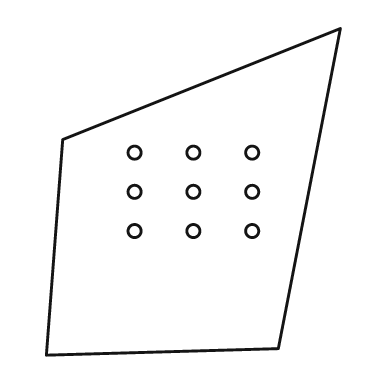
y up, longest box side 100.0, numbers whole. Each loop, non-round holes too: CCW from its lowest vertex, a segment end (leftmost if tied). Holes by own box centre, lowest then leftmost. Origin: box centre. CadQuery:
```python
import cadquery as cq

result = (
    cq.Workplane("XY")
    .moveTo(-45.0, -50.0)
    .lineTo(26.0, -48.0)
    .lineTo(45.0, 50.0)
    .lineTo(-40.0, 16.0)
    .close()
    .moveTo(-18.0, -12.0)
    .circle(2.0)
    .moveTo(0.0, -12.0)
    .circle(2.0)
    .moveTo(18.0, -12.0)
    .circle(2.0)
    .moveTo(-18.0, 0.0)
    .circle(2.0)
    .moveTo(0.0, 0.0)
    .circle(2.0)
    .moveTo(18.0, 0.0)
    .circle(2.0)
    .moveTo(-18.0, 12.0)
    .circle(2.0)
    .moveTo(0.0, 12.0)
    .circle(2.0)
    .moveTo(18.0, 12.0)
    .circle(2.0)
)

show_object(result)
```